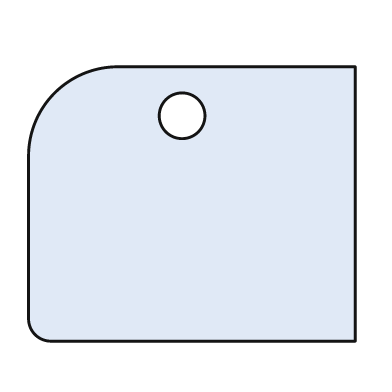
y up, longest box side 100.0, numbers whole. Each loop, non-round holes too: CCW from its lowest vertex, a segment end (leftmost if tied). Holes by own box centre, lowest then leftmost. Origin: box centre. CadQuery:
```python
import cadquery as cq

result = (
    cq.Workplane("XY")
    .moveTo(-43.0, -42.0)
    .lineTo(50.0, -42.0)
    .lineTo(50.0, 42.0)
    .lineTo(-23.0, 42.0)
    .threePointArc((-42.0, 34.0), (-50.0, 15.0))
    .lineTo(-50.0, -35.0)
    .threePointArc((-48.0, -40.0), (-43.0, -42.0))
    .close()
    .moveTo(-3.0, 27.0)
    .circle(7.0)
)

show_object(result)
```